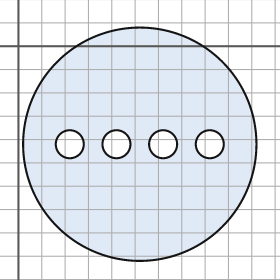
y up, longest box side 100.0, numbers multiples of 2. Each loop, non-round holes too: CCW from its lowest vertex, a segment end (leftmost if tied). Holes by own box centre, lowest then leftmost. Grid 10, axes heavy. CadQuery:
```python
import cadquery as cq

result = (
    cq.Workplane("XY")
    .moveTo(52.0, -42.0)
    .circle(50.0)
    .moveTo(22.0, -42.0)
    .circle(6.0)
    .moveTo(42.0, -42.0)
    .circle(6.0)
    .moveTo(62.0, -42.0)
    .circle(6.0)
    .moveTo(82.0, -42.0)
    .circle(6.0)
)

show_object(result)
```